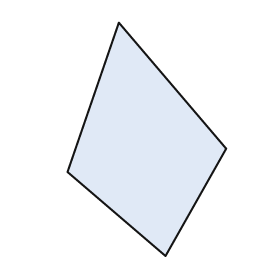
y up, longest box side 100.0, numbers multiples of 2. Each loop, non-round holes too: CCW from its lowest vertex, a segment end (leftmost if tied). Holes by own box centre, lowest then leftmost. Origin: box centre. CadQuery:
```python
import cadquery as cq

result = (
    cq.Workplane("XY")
    .moveTo(8.0, -50.0)
    .lineTo(34.0, -4.0)
    .lineTo(-12.0, 50.0)
    .lineTo(-34.0, -14.0)
    .close()
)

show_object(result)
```